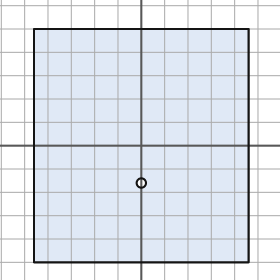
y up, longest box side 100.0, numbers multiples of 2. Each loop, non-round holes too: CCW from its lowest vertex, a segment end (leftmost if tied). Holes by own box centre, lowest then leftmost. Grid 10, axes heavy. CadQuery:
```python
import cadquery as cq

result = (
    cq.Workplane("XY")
    .moveTo(-46.0, -50.0)
    .lineTo(46.0, -50.0)
    .lineTo(46.0, 50.0)
    .lineTo(-46.0, 50.0)
    .close()
    .moveTo(0.0, -16.0)
    .circle(2.0)
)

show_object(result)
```